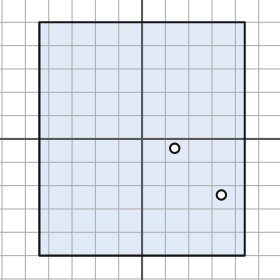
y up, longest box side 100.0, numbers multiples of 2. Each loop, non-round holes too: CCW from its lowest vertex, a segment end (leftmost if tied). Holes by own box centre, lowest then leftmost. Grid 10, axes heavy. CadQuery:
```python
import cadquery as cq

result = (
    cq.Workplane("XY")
    .moveTo(-44.0, -50.0)
    .lineTo(44.0, -50.0)
    .lineTo(44.0, 50.0)
    .lineTo(-44.0, 50.0)
    .close()
    .moveTo(34.0, -24.0)
    .circle(2.0)
    .moveTo(14.0, -4.0)
    .circle(2.0)
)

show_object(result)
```